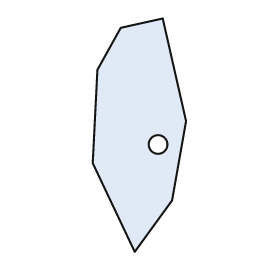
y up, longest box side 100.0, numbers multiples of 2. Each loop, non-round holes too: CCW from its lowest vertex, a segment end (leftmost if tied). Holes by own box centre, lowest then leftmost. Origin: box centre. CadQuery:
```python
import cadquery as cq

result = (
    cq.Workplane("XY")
    .moveTo(-2.0, -50.0)
    .lineTo(14.0, -28.0)
    .lineTo(20.0, 6.0)
    .lineTo(10.0, 50.0)
    .lineTo(-8.0, 46.0)
    .lineTo(-18.0, 28.0)
    .lineTo(-20.0, -12.0)
    .close()
    .moveTo(8.0, -4.0)
    .circle(4.0)
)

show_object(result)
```